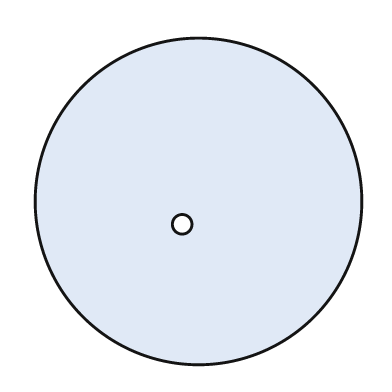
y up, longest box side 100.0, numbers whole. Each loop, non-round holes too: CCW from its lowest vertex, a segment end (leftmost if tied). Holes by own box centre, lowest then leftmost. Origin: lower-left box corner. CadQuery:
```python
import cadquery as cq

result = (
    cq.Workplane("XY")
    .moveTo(50.0, 50.0)
    .circle(50.0)
    .moveTo(45.0, 43.0)
    .circle(3.0)
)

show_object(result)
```